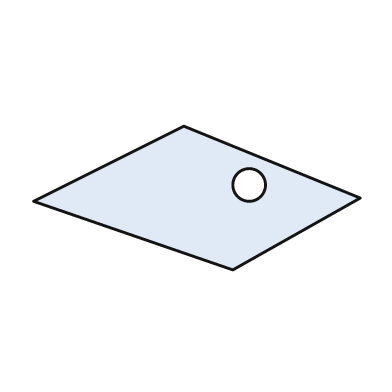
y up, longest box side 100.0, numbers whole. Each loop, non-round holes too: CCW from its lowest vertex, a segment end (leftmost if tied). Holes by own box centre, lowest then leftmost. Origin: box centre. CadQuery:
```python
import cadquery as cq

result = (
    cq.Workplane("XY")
    .moveTo(11.0, -22.0)
    .lineTo(50.0, 0.0)
    .lineTo(-4.0, 22.0)
    .lineTo(-50.0, -1.0)
    .close()
    .moveTo(16.0, 4.0)
    .circle(5.0)
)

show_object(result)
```